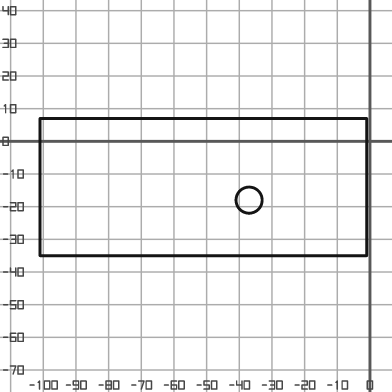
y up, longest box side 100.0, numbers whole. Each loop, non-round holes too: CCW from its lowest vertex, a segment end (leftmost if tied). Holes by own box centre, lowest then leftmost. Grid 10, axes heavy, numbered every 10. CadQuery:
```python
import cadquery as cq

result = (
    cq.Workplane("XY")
    .moveTo(-101.0, -35.0)
    .lineTo(-1.0, -35.0)
    .lineTo(-1.0, 7.0)
    .lineTo(-101.0, 7.0)
    .close()
    .moveTo(-37.0, -18.0)
    .circle(4.0)
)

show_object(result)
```